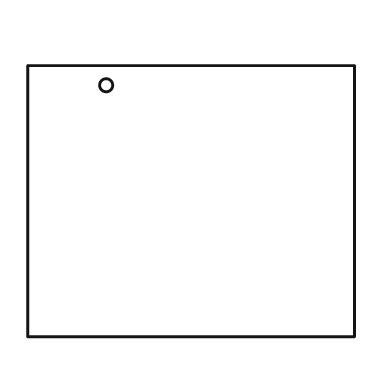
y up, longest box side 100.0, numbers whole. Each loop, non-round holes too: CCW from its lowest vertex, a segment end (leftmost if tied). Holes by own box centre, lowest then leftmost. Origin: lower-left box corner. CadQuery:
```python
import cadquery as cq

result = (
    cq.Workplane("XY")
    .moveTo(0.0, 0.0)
    .lineTo(100.0, 0.0)
    .lineTo(100.0, 83.0)
    .lineTo(0.0, 83.0)
    .close()
    .moveTo(24.0, 77.0)
    .circle(2.0)
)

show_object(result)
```